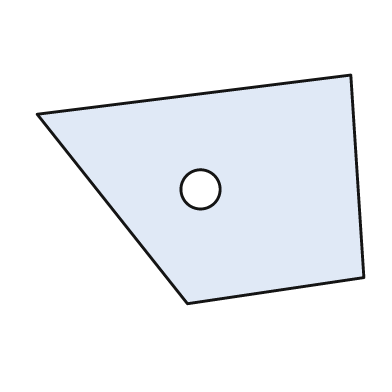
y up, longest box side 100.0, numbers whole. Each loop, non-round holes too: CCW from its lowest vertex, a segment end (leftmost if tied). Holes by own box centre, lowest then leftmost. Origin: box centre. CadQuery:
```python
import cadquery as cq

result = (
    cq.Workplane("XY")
    .moveTo(-4.0, -35.0)
    .lineTo(50.0, -27.0)
    .lineTo(46.0, 35.0)
    .lineTo(-50.0, 23.0)
    .close()
    .moveTo(0.0, 0.0)
    .circle(6.0)
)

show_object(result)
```